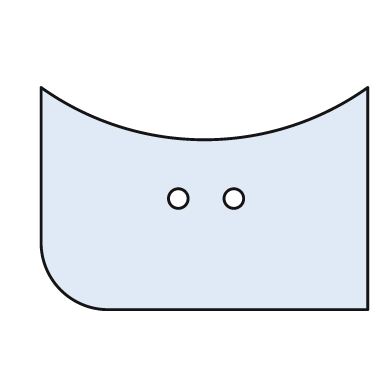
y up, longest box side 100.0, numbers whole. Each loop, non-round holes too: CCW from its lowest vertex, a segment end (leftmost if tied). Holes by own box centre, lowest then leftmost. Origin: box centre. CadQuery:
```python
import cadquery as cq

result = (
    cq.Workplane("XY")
    .moveTo(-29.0, -34.0)
    .lineTo(50.0, -34.0)
    .lineTo(50.0, 34.0)
    .threePointArc((0.0, 18.0), (-50.0, 34.0))
    .lineTo(-50.0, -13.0)
    .threePointArc((-44.0, -28.0), (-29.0, -34.0))
    .close()
    .moveTo(-8.0, 0.0)
    .circle(3.0)
    .moveTo(9.0, 0.0)
    .circle(3.0)
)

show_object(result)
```